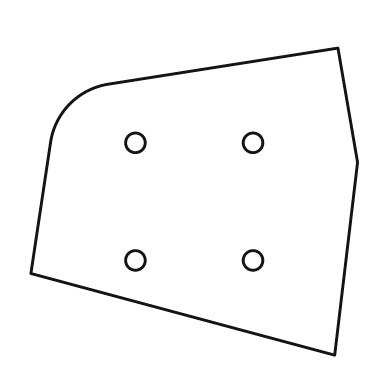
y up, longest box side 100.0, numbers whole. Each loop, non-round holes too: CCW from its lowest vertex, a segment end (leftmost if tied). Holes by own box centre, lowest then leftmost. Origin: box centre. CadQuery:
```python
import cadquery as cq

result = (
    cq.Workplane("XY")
    .moveTo(43.0, -47.0)
    .lineTo(50.0, 12.0)
    .lineTo(44.0, 47.0)
    .lineTo(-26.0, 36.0)
    .threePointArc((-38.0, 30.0), (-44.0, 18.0))
    .lineTo(-50.0, -22.0)
    .close()
    .moveTo(-18.0, -18.0)
    .circle(3.0)
    .moveTo(18.0, -18.0)
    .circle(3.0)
    .moveTo(-18.0, 18.0)
    .circle(3.0)
    .moveTo(18.0, 18.0)
    .circle(3.0)
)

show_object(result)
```